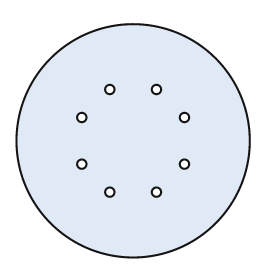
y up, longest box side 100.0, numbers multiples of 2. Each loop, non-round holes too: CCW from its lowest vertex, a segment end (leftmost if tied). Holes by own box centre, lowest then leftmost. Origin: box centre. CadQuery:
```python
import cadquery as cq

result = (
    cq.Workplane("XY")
    .moveTo(0.0, 0.0)
    .circle(50.0)
    .moveTo(-10.0, -22.0)
    .circle(2.0)
    .moveTo(10.0, -22.0)
    .circle(2.0)
    .moveTo(-22.0, -10.0)
    .circle(2.0)
    .moveTo(22.0, -10.0)
    .circle(2.0)
    .moveTo(-22.0, 10.0)
    .circle(2.0)
    .moveTo(22.0, 10.0)
    .circle(2.0)
    .moveTo(-10.0, 22.0)
    .circle(2.0)
    .moveTo(10.0, 22.0)
    .circle(2.0)
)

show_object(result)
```